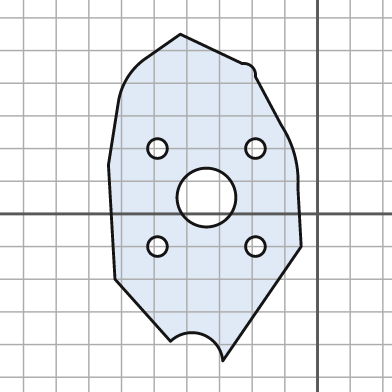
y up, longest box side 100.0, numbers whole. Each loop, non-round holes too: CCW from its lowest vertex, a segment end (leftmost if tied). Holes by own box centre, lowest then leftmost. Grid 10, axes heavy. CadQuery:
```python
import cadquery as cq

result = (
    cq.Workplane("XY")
    .moveTo(-29.0, -45.0)
    .lineTo(-5.0, -10.0)
    .lineTo(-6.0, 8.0)
    .threePointArc((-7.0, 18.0), (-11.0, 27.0))
    .lineTo(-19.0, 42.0)
    .threePointArc((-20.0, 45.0), (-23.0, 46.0))
    .lineTo(-42.0, 55.0)
    .lineTo(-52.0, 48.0)
    .threePointArc((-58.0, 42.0), (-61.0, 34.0))
    .lineTo(-64.0, 15.0)
    .lineTo(-62.0, -20.0)
    .lineTo(-45.0, -39.0)
    .threePointArc((-35.0, -37.0), (-29.0, -45.0))
    .close()
    .moveTo(-49.0, -10.0)
    .circle(3.0)
    .moveTo(-19.0, -10.0)
    .circle(3.0)
    .moveTo(-34.0, 5.0)
    .circle(9.0)
    .moveTo(-49.0, 20.0)
    .circle(3.0)
    .moveTo(-19.0, 20.0)
    .circle(3.0)
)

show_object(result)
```